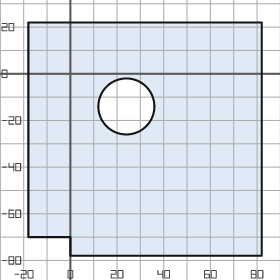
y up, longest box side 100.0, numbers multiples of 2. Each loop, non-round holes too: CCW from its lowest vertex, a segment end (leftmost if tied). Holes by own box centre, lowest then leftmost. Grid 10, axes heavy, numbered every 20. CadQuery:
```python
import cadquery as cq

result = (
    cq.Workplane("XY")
    .moveTo(0.0, -78.0)
    .lineTo(82.0, -78.0)
    .lineTo(82.0, 22.0)
    .lineTo(-18.0, 22.0)
    .lineTo(-18.0, -70.0)
    .lineTo(0.0, -70.0)
    .close()
    .moveTo(24.0, -14.0)
    .circle(12.0)
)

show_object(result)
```